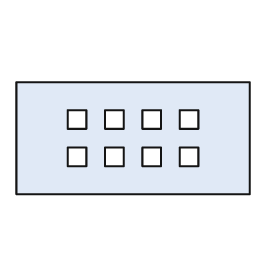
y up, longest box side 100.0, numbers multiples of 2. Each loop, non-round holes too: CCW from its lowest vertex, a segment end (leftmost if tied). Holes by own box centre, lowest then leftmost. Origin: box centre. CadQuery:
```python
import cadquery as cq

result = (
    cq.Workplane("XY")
    .moveTo(-50.0, -24.0)
    .lineTo(50.0, -24.0)
    .lineTo(50.0, 24.0)
    .lineTo(-50.0, 24.0)
    .close()
    .moveTo(-28.0, -12.0)
    .lineTo(-20.0, -12.0)
    .lineTo(-20.0, -4.0)
    .lineTo(-28.0, -4.0)
    .close()
    .moveTo(-12.0, -12.0)
    .lineTo(-4.0, -12.0)
    .lineTo(-4.0, -4.0)
    .lineTo(-12.0, -4.0)
    .close()
    .moveTo(4.0, -12.0)
    .lineTo(12.0, -12.0)
    .lineTo(12.0, -4.0)
    .lineTo(4.0, -4.0)
    .close()
    .moveTo(20.0, -12.0)
    .lineTo(28.0, -12.0)
    .lineTo(28.0, -4.0)
    .lineTo(20.0, -4.0)
    .close()
    .moveTo(-28.0, 4.0)
    .lineTo(-20.0, 4.0)
    .lineTo(-20.0, 12.0)
    .lineTo(-28.0, 12.0)
    .close()
    .moveTo(-12.0, 4.0)
    .lineTo(-4.0, 4.0)
    .lineTo(-4.0, 12.0)
    .lineTo(-12.0, 12.0)
    .close()
    .moveTo(4.0, 4.0)
    .lineTo(12.0, 4.0)
    .lineTo(12.0, 12.0)
    .lineTo(4.0, 12.0)
    .close()
    .moveTo(20.0, 4.0)
    .lineTo(28.0, 4.0)
    .lineTo(28.0, 12.0)
    .lineTo(20.0, 12.0)
    .close()
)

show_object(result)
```